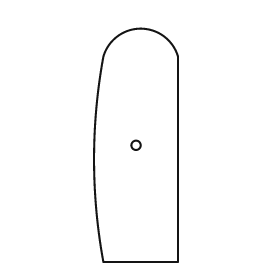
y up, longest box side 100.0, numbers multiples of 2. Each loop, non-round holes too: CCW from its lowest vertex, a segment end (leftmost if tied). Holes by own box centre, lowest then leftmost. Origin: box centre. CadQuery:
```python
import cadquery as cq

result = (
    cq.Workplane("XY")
    .moveTo(-14.0, -50.0)
    .lineTo(18.0, -50.0)
    .lineTo(18.0, 38.0)
    .threePointArc((2.0, 50.0), (-14.0, 38.0))
    .threePointArc((-18.0, -6.0), (-14.0, -50.0))
    .close()
    .moveTo(0.0, 0.0)
    .circle(2.0)
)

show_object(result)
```